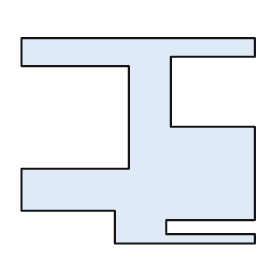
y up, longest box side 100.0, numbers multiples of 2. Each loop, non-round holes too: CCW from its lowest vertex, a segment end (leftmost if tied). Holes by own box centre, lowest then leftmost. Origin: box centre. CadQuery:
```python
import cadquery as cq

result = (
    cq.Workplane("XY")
    .moveTo(-10.0, -44.0)
    .lineTo(50.0, -44.0)
    .lineTo(50.0, -40.0)
    .lineTo(12.0, -40.0)
    .lineTo(12.0, -34.0)
    .lineTo(50.0, -34.0)
    .lineTo(50.0, 6.0)
    .lineTo(14.0, 6.0)
    .lineTo(14.0, 36.0)
    .lineTo(50.0, 36.0)
    .lineTo(50.0, 44.0)
    .lineTo(-50.0, 44.0)
    .lineTo(-50.0, 32.0)
    .lineTo(-4.0, 32.0)
    .lineTo(-4.0, -12.0)
    .lineTo(-50.0, -12.0)
    .lineTo(-50.0, -30.0)
    .lineTo(-10.0, -30.0)
    .close()
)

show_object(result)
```